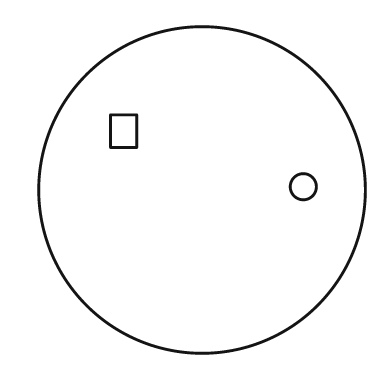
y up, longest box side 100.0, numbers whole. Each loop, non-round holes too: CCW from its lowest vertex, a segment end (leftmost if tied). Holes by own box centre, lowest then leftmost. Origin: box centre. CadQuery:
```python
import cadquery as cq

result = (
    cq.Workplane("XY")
    .moveTo(0.0, 0.0)
    .circle(50.0)
    .moveTo(31.0, 1.0)
    .circle(4.0)
    .moveTo(-28.0, 13.0)
    .lineTo(-20.0, 13.0)
    .lineTo(-20.0, 23.0)
    .lineTo(-28.0, 23.0)
    .close()
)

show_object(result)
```